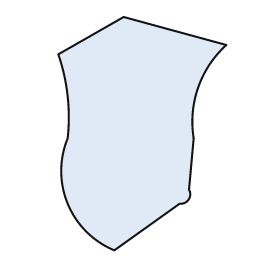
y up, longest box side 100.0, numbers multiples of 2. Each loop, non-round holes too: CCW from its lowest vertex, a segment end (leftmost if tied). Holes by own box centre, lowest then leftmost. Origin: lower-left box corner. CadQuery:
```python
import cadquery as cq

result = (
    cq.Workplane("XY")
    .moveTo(24.0, 0.0)
    .lineTo(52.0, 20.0)
    .threePointArc((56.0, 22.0), (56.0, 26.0))
    .lineTo(58.0, 48.0)
    .threePointArc((60.0, 70.0), (72.0, 88.0))
    .lineTo(28.0, 100.0)
    .lineTo(0.0, 84.0)
    .threePointArc((4.0, 66.0), (4.0, 48.0))
    .threePointArc((4.0, 20.0), (24.0, 0.0))
    .close()
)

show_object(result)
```